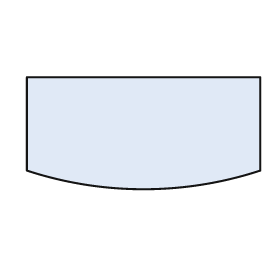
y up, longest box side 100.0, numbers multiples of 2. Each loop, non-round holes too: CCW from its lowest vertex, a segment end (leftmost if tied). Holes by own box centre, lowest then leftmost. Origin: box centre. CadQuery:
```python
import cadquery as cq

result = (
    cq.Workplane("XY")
    .moveTo(-50.0, -16.0)
    .threePointArc((0.0, -24.0), (50.0, -16.0))
    .lineTo(50.0, 24.0)
    .lineTo(-50.0, 24.0)
    .close()
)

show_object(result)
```